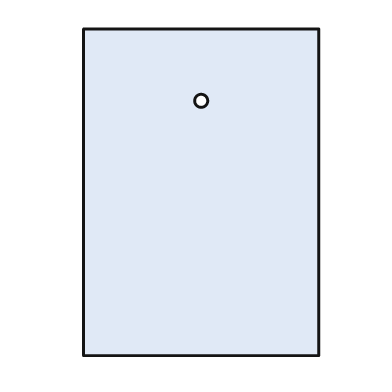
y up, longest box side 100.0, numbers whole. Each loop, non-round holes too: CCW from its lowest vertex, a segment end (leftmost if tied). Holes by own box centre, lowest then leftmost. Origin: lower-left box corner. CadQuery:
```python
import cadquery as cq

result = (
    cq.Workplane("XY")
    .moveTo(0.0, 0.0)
    .lineTo(72.0, 0.0)
    .lineTo(72.0, 100.0)
    .lineTo(0.0, 100.0)
    .close()
    .moveTo(36.0, 78.0)
    .circle(2.0)
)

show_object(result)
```